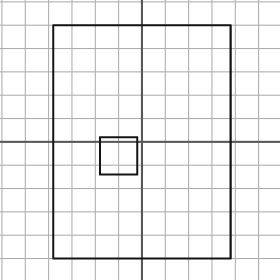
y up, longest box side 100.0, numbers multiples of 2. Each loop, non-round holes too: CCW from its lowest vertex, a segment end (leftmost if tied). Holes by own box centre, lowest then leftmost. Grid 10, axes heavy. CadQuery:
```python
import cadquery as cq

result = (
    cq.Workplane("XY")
    .moveTo(-38.0, -50.0)
    .lineTo(38.0, -50.0)
    .lineTo(38.0, 50.0)
    .lineTo(-38.0, 50.0)
    .close()
    .moveTo(-18.0, -14.0)
    .lineTo(-2.0, -14.0)
    .lineTo(-2.0, 2.0)
    .lineTo(-18.0, 2.0)
    .close()
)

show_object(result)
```